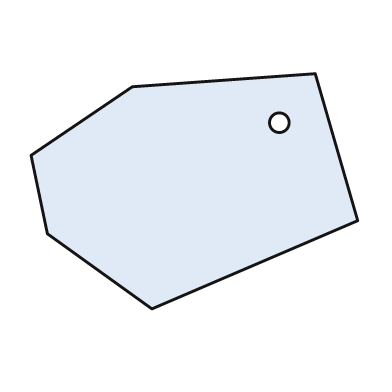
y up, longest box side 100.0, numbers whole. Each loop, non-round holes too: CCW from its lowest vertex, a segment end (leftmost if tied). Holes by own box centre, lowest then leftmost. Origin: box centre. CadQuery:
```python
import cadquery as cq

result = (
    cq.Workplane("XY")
    .moveTo(-13.0, -36.0)
    .lineTo(50.0, -9.0)
    .lineTo(37.0, 36.0)
    .lineTo(-19.0, 32.0)
    .lineTo(-50.0, 11.0)
    .lineTo(-45.0, -13.0)
    .close()
    .moveTo(26.0, 21.0)
    .circle(3.0)
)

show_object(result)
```